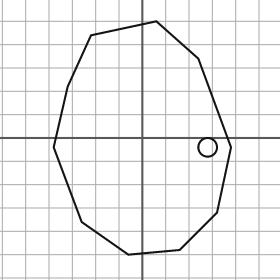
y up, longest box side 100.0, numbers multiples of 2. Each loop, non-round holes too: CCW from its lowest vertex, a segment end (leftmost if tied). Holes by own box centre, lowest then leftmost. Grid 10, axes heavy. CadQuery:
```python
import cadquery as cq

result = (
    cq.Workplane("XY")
    .moveTo(-6.0, -50.0)
    .lineTo(16.0, -48.0)
    .lineTo(32.0, -32.0)
    .lineTo(38.0, -4.0)
    .lineTo(24.0, 34.0)
    .lineTo(6.0, 50.0)
    .lineTo(-22.0, 44.0)
    .lineTo(-32.0, 22.0)
    .lineTo(-38.0, -4.0)
    .lineTo(-26.0, -36.0)
    .close()
    .moveTo(28.0, -4.0)
    .circle(4.0)
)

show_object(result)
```